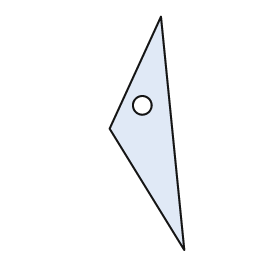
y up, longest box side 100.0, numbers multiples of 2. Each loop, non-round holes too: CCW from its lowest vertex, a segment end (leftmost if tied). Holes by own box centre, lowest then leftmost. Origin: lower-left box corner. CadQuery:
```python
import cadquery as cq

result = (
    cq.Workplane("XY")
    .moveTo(32.0, 0.0)
    .lineTo(22.0, 100.0)
    .lineTo(0.0, 52.0)
    .close()
    .moveTo(14.0, 62.0)
    .circle(4.0)
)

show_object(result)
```